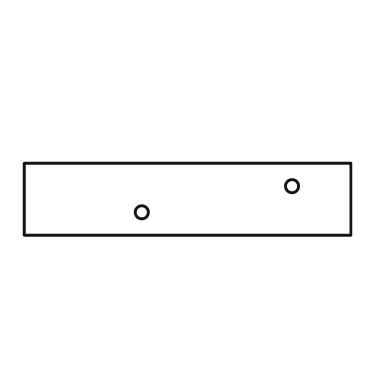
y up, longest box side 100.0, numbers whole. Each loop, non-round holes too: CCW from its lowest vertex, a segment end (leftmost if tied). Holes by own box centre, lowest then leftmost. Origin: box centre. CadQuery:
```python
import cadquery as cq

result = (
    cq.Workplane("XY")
    .moveTo(-50.0, -11.0)
    .lineTo(50.0, -11.0)
    .lineTo(50.0, 11.0)
    .lineTo(-50.0, 11.0)
    .close()
    .moveTo(-14.0, -4.0)
    .circle(2.0)
    .moveTo(32.0, 4.0)
    .circle(2.0)
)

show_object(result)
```